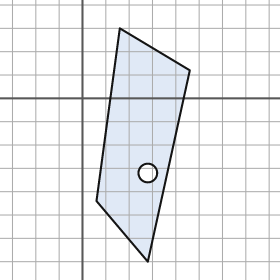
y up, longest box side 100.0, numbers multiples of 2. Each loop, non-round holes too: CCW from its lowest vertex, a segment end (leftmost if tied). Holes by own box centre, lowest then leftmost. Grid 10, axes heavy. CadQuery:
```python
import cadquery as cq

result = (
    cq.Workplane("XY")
    .moveTo(28.0, -70.0)
    .lineTo(46.0, 12.0)
    .lineTo(16.0, 30.0)
    .lineTo(6.0, -44.0)
    .close()
    .moveTo(28.0, -32.0)
    .circle(4.0)
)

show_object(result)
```